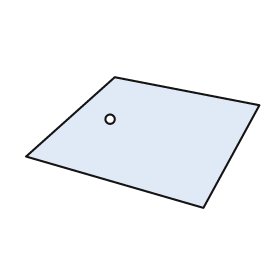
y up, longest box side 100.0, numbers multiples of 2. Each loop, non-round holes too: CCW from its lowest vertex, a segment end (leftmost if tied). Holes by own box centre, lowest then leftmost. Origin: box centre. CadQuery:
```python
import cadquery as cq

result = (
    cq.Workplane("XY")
    .moveTo(26.0, -28.0)
    .lineTo(50.0, 16.0)
    .lineTo(-12.0, 28.0)
    .lineTo(-50.0, -6.0)
    .close()
    .moveTo(-14.0, 10.0)
    .circle(2.0)
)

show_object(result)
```